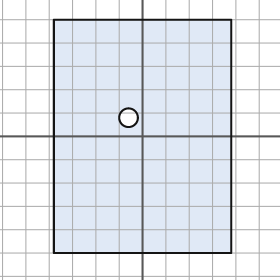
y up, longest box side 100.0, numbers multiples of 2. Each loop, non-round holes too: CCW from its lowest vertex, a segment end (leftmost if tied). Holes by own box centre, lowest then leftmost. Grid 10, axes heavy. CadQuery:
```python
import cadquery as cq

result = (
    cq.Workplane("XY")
    .moveTo(-38.0, -50.0)
    .lineTo(38.0, -50.0)
    .lineTo(38.0, 50.0)
    .lineTo(-38.0, 50.0)
    .close()
    .moveTo(-6.0, 8.0)
    .circle(4.0)
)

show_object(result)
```